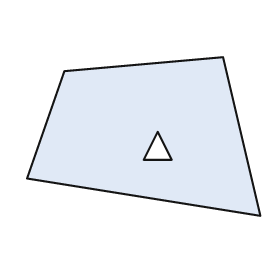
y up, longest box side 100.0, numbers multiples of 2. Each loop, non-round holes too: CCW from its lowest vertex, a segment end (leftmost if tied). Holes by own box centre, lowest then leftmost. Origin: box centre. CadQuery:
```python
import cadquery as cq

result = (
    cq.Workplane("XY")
    .moveTo(50.0, -34.0)
    .lineTo(34.0, 34.0)
    .lineTo(-34.0, 28.0)
    .lineTo(-50.0, -18.0)
    .close()
    .moveTo(0.0, -10.0)
    .lineTo(12.0, -10.0)
    .lineTo(6.0, 2.0)
    .close()
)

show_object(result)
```